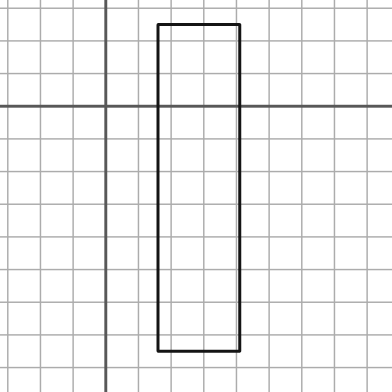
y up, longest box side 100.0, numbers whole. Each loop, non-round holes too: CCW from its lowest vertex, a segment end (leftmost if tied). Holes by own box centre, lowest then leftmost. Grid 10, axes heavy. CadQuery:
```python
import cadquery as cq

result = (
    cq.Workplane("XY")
    .moveTo(16.0, -75.0)
    .lineTo(41.0, -75.0)
    .lineTo(41.0, 25.0)
    .lineTo(16.0, 25.0)
    .close()
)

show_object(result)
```